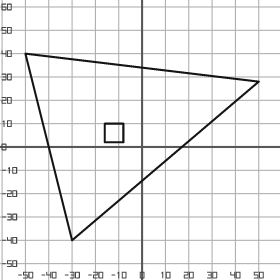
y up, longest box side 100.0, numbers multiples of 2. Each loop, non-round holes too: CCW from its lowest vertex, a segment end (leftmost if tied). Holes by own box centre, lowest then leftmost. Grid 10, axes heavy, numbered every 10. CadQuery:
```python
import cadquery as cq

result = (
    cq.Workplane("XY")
    .moveTo(-30.0, -40.0)
    .lineTo(50.0, 28.0)
    .lineTo(-50.0, 40.0)
    .close()
    .moveTo(-16.0, 2.0)
    .lineTo(-8.0, 2.0)
    .lineTo(-8.0, 10.0)
    .lineTo(-16.0, 10.0)
    .close()
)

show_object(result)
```